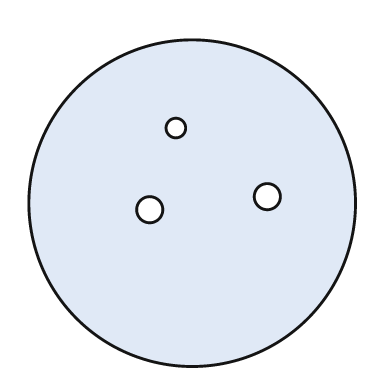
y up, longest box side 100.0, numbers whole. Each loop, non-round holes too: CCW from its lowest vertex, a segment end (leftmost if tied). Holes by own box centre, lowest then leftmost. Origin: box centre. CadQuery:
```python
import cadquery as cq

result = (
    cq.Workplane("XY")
    .moveTo(0.0, 0.0)
    .circle(50.0)
    .moveTo(-13.0, -2.0)
    .circle(4.0)
    .moveTo(23.0, 2.0)
    .circle(4.0)
    .moveTo(-5.0, 23.0)
    .circle(3.0)
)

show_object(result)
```